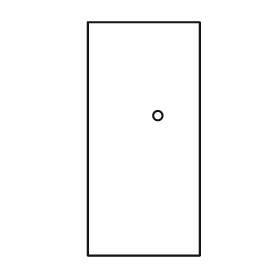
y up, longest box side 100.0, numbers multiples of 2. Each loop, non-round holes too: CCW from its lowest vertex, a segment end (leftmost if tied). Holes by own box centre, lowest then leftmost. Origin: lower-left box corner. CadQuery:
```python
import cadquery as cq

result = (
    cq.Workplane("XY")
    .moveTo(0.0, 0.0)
    .lineTo(48.0, 0.0)
    .lineTo(48.0, 100.0)
    .lineTo(0.0, 100.0)
    .close()
    .moveTo(30.0, 60.0)
    .circle(2.0)
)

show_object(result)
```